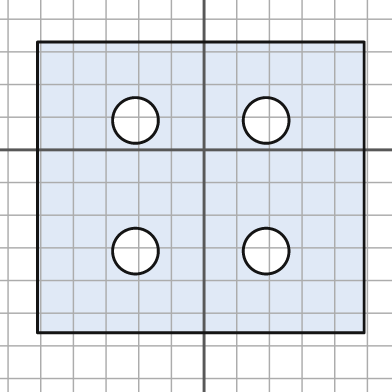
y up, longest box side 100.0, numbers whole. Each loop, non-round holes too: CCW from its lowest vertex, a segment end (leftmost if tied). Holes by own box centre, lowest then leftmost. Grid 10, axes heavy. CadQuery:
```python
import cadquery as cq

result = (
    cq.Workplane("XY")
    .moveTo(-51.0, -56.0)
    .lineTo(49.0, -56.0)
    .lineTo(49.0, 33.0)
    .lineTo(-51.0, 33.0)
    .close()
    .moveTo(-21.0, -31.0)
    .circle(7.0)
    .moveTo(19.0, -31.0)
    .circle(7.0)
    .moveTo(-21.0, 9.0)
    .circle(7.0)
    .moveTo(19.0, 9.0)
    .circle(7.0)
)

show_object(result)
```